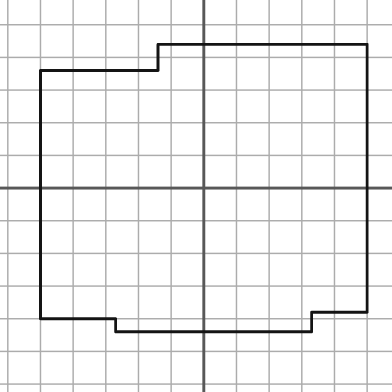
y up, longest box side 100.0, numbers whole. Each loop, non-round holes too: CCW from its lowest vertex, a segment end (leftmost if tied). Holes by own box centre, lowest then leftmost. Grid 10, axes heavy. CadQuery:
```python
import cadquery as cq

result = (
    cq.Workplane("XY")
    .moveTo(-27.0, -44.0)
    .lineTo(33.0, -44.0)
    .lineTo(33.0, -38.0)
    .lineTo(50.0, -38.0)
    .lineTo(50.0, 44.0)
    .lineTo(-14.0, 44.0)
    .lineTo(-14.0, 36.0)
    .lineTo(-50.0, 36.0)
    .lineTo(-50.0, -40.0)
    .lineTo(-27.0, -40.0)
    .close()
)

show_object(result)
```